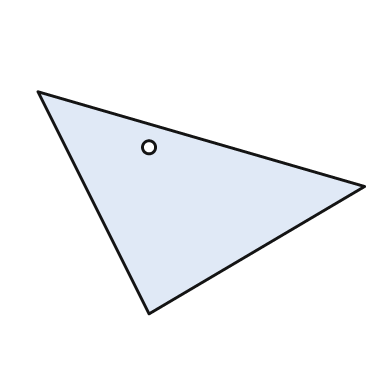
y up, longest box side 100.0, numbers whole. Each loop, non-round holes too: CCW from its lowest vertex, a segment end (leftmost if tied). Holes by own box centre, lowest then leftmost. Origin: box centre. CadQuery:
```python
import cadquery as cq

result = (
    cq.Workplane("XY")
    .moveTo(-16.0, -34.0)
    .lineTo(50.0, 5.0)
    .lineTo(-50.0, 34.0)
    .close()
    .moveTo(-16.0, 17.0)
    .circle(2.0)
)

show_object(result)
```